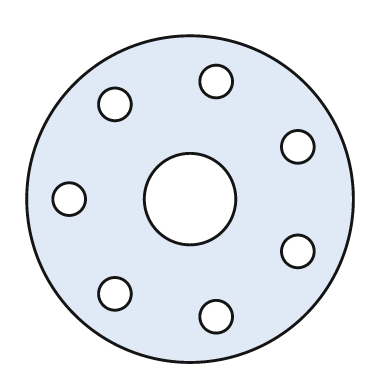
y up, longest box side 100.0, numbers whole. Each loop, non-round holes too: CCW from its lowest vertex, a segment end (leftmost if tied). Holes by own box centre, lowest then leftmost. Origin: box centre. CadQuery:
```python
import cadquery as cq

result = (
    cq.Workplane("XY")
    .moveTo(0.0, 0.0)
    .circle(50.0)
    .moveTo(8.0, -36.0)
    .circle(5.0)
    .moveTo(-23.0, -29.0)
    .circle(5.0)
    .moveTo(33.0, -16.0)
    .circle(5.0)
    .moveTo(-37.0, 0.0)
    .circle(5.0)
    .moveTo(0.0, 0.0)
    .circle(14.0)
    .moveTo(33.0, 16.0)
    .circle(5.0)
    .moveTo(-23.0, 29.0)
    .circle(5.0)
    .moveTo(8.0, 36.0)
    .circle(5.0)
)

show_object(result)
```